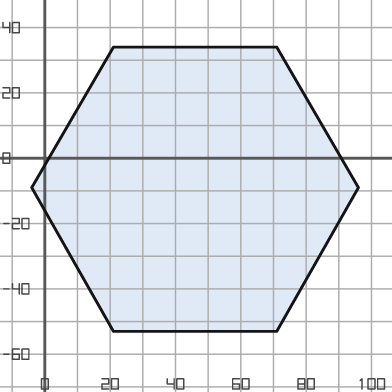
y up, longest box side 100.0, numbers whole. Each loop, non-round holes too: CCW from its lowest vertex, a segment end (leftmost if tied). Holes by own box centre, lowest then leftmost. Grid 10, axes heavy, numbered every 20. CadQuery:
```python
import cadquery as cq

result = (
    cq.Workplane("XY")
    .moveTo(21.0, -53.0)
    .lineTo(71.0, -53.0)
    .lineTo(96.0, -9.0)
    .lineTo(71.0, 34.0)
    .lineTo(21.0, 34.0)
    .lineTo(-4.0, -9.0)
    .close()
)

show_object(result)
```